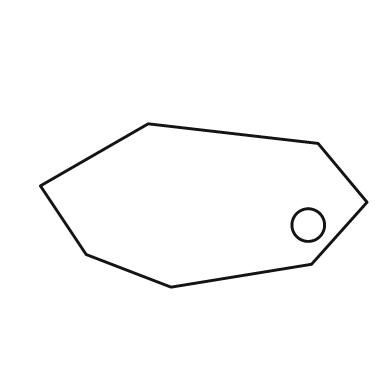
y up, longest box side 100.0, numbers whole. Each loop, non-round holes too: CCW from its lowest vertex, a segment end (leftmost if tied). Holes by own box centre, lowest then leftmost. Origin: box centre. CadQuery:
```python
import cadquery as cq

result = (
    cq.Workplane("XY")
    .moveTo(-10.0, -25.0)
    .lineTo(33.0, -18.0)
    .lineTo(50.0, 1.0)
    .lineTo(35.0, 19.0)
    .lineTo(-17.0, 25.0)
    .lineTo(-50.0, 6.0)
    .lineTo(-36.0, -15.0)
    .close()
    .moveTo(32.0, -6.0)
    .circle(5.0)
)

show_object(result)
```